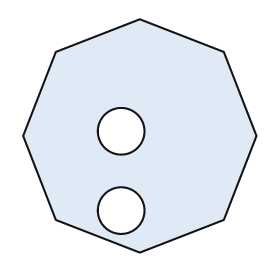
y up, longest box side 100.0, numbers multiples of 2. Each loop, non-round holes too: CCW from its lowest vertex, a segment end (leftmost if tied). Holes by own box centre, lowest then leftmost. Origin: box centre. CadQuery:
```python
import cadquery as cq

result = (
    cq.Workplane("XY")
    .moveTo(0.0, -50.0)
    .lineTo(36.0, -36.0)
    .lineTo(50.0, 0.0)
    .lineTo(36.0, 36.0)
    .lineTo(0.0, 50.0)
    .lineTo(-36.0, 36.0)
    .lineTo(-50.0, 0.0)
    .lineTo(-36.0, -36.0)
    .close()
    .moveTo(-8.0, -32.0)
    .circle(10.0)
    .moveTo(-8.0, 2.0)
    .circle(10.0)
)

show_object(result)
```